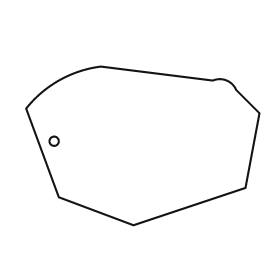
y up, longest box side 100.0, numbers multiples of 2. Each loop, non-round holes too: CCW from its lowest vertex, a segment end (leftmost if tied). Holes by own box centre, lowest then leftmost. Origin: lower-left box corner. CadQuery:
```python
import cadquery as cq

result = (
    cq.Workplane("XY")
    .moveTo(46.0, 0.0)
    .lineTo(94.0, 16.0)
    .lineTo(100.0, 48.0)
    .lineTo(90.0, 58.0)
    .threePointArc((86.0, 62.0), (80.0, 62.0))
    .lineTo(32.0, 68.0)
    .threePointArc((14.0, 62.0), (0.0, 50.0))
    .lineTo(14.0, 12.0)
    .close()
    .moveTo(12.0, 36.0)
    .circle(2.0)
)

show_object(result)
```